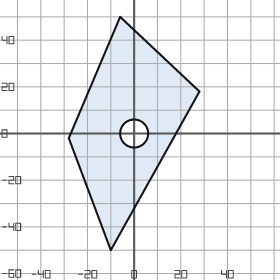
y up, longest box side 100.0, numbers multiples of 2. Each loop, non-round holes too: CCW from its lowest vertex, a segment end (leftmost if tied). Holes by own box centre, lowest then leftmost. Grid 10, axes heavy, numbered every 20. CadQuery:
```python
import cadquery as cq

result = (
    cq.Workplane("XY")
    .moveTo(-10.0, -50.0)
    .lineTo(28.0, 18.0)
    .lineTo(-6.0, 50.0)
    .lineTo(-28.0, -2.0)
    .close()
    .moveTo(0.0, 0.0)
    .circle(6.0)
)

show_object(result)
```